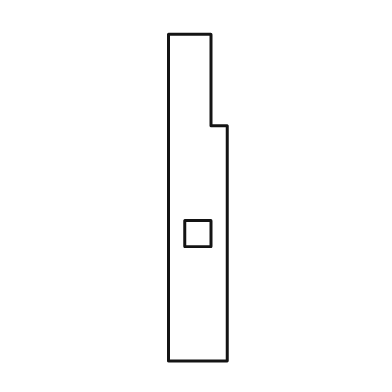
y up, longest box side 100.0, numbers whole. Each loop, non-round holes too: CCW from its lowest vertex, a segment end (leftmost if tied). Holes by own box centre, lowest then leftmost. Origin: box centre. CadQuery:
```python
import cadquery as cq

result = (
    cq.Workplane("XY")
    .moveTo(-9.0, -50.0)
    .lineTo(9.0, -50.0)
    .lineTo(9.0, 22.0)
    .lineTo(4.0, 22.0)
    .lineTo(4.0, 50.0)
    .lineTo(-9.0, 50.0)
    .close()
    .moveTo(-4.0, -15.0)
    .lineTo(4.0, -15.0)
    .lineTo(4.0, -7.0)
    .lineTo(-4.0, -7.0)
    .close()
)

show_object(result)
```